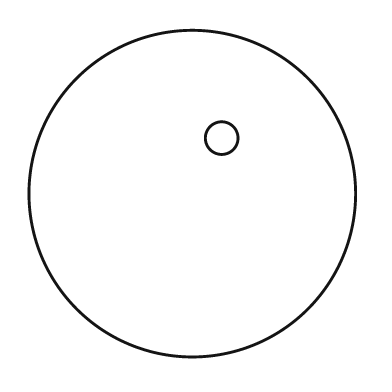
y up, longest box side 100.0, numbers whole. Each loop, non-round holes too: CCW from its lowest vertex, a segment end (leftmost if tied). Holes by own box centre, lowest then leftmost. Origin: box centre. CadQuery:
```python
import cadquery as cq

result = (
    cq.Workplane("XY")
    .moveTo(0.0, 0.0)
    .circle(50.0)
    .moveTo(9.0, 17.0)
    .circle(5.0)
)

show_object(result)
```